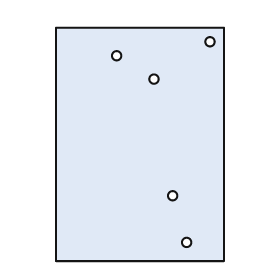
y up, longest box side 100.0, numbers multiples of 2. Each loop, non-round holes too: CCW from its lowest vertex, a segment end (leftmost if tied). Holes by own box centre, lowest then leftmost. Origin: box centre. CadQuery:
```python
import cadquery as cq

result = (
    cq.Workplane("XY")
    .moveTo(-36.0, -50.0)
    .lineTo(36.0, -50.0)
    .lineTo(36.0, 50.0)
    .lineTo(-36.0, 50.0)
    .close()
    .moveTo(20.0, -42.0)
    .circle(2.0)
    .moveTo(14.0, -22.0)
    .circle(2.0)
    .moveTo(6.0, 28.0)
    .circle(2.0)
    .moveTo(-10.0, 38.0)
    .circle(2.0)
    .moveTo(30.0, 44.0)
    .circle(2.0)
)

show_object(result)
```